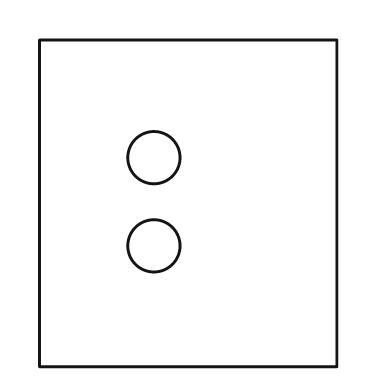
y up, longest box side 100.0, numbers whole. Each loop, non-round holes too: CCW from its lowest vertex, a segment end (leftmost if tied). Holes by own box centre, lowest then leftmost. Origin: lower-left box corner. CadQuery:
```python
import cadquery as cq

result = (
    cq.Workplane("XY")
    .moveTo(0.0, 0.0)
    .lineTo(91.0, 0.0)
    .lineTo(91.0, 100.0)
    .lineTo(0.0, 100.0)
    .close()
    .moveTo(35.0, 37.0)
    .circle(8.0)
    .moveTo(35.0, 64.0)
    .circle(8.0)
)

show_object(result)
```